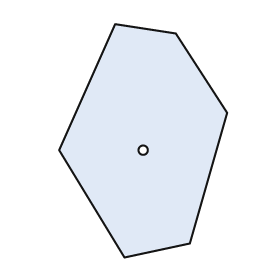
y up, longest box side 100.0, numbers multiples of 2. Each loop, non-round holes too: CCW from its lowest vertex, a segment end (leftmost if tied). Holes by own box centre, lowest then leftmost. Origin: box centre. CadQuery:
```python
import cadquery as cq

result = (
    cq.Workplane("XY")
    .moveTo(-8.0, -50.0)
    .lineTo(20.0, -44.0)
    .lineTo(36.0, 12.0)
    .lineTo(14.0, 46.0)
    .lineTo(-12.0, 50.0)
    .lineTo(-36.0, -4.0)
    .close()
    .moveTo(0.0, -4.0)
    .circle(2.0)
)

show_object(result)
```